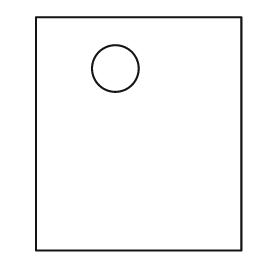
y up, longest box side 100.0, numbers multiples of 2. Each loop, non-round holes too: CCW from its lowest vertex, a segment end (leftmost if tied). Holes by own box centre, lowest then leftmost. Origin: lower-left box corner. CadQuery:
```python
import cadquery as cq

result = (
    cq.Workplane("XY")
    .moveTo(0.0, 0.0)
    .lineTo(88.0, 0.0)
    .lineTo(88.0, 100.0)
    .lineTo(0.0, 100.0)
    .close()
    .moveTo(34.0, 78.0)
    .circle(10.0)
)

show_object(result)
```